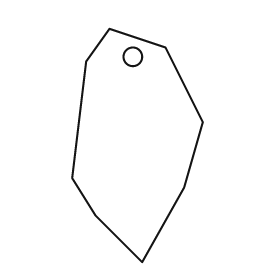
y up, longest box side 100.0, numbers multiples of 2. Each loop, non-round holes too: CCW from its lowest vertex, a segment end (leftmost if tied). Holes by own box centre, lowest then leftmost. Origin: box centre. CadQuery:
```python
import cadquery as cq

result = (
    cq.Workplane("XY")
    .moveTo(2.0, -50.0)
    .lineTo(20.0, -18.0)
    .lineTo(28.0, 10.0)
    .lineTo(12.0, 42.0)
    .lineTo(-12.0, 50.0)
    .lineTo(-22.0, 36.0)
    .lineTo(-28.0, -14.0)
    .lineTo(-18.0, -30.0)
    .close()
    .moveTo(-2.0, 38.0)
    .circle(4.0)
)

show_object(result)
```